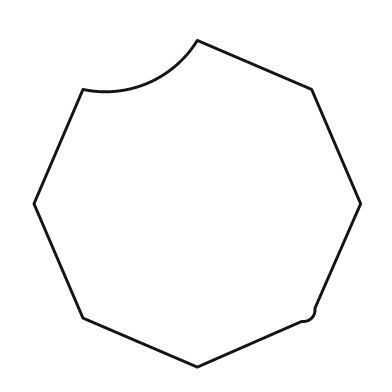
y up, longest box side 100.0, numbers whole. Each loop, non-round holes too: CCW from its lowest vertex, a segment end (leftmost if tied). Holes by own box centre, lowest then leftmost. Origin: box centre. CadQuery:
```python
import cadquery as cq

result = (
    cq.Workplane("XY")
    .moveTo(0.0, -50.0)
    .lineTo(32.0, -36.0)
    .threePointArc((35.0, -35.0), (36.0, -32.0))
    .lineTo(50.0, 0.0)
    .lineTo(35.0, 35.0)
    .lineTo(0.0, 50.0)
    .threePointArc((-15.0, 37.0), (-35.0, 35.0))
    .lineTo(-50.0, 0.0)
    .lineTo(-35.0, -35.0)
    .close()
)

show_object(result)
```